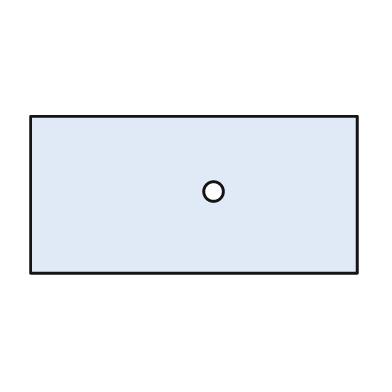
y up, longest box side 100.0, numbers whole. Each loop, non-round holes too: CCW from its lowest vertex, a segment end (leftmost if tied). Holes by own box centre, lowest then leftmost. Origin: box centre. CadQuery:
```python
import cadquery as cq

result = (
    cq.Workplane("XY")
    .moveTo(-50.0, -24.0)
    .lineTo(50.0, -24.0)
    .lineTo(50.0, 24.0)
    .lineTo(-50.0, 24.0)
    .close()
    .moveTo(6.0, 1.0)
    .circle(3.0)
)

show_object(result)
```